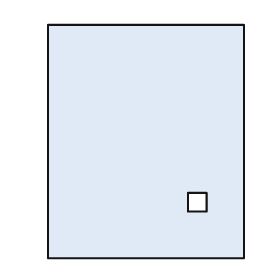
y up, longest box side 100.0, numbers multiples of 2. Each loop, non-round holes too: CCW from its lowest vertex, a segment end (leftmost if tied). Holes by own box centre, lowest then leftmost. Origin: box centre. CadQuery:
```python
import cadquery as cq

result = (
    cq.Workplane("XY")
    .moveTo(-42.0, -50.0)
    .lineTo(42.0, -50.0)
    .lineTo(42.0, 50.0)
    .lineTo(-42.0, 50.0)
    .close()
    .moveTo(18.0, -30.0)
    .lineTo(26.0, -30.0)
    .lineTo(26.0, -22.0)
    .lineTo(18.0, -22.0)
    .close()
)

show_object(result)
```